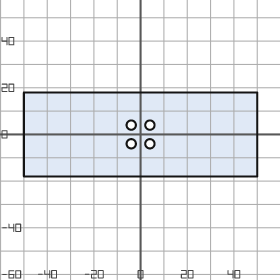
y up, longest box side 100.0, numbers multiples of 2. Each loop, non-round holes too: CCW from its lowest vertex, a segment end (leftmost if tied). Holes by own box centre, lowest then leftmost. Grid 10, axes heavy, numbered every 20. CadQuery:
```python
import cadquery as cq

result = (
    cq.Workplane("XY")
    .moveTo(-50.0, -18.0)
    .lineTo(50.0, -18.0)
    .lineTo(50.0, 18.0)
    .lineTo(-50.0, 18.0)
    .close()
    .moveTo(-4.0, -4.0)
    .circle(2.0)
    .moveTo(4.0, -4.0)
    .circle(2.0)
    .moveTo(-4.0, 4.0)
    .circle(2.0)
    .moveTo(4.0, 4.0)
    .circle(2.0)
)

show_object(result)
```